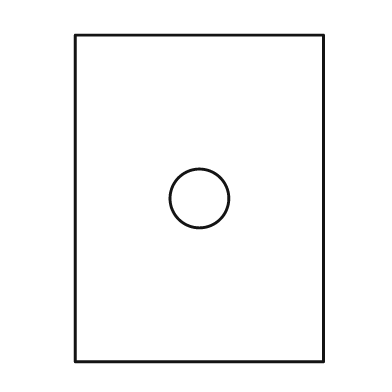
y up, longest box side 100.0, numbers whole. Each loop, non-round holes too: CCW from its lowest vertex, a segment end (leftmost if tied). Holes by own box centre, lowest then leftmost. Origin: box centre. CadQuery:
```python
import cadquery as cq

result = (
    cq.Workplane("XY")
    .moveTo(-38.0, -50.0)
    .lineTo(38.0, -50.0)
    .lineTo(38.0, 50.0)
    .lineTo(-38.0, 50.0)
    .close()
    .moveTo(0.0, 0.0)
    .circle(9.0)
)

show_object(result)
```